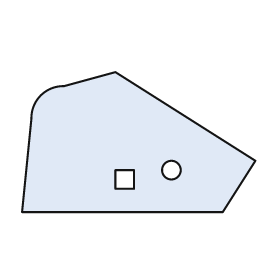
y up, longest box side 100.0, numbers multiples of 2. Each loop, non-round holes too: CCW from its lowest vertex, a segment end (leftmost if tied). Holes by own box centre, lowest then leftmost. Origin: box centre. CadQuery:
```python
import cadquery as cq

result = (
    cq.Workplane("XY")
    .moveTo(-50.0, -30.0)
    .lineTo(36.0, -30.0)
    .lineTo(50.0, -8.0)
    .lineTo(-10.0, 30.0)
    .lineTo(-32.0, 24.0)
    .threePointArc((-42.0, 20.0), (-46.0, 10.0))
    .close()
    .moveTo(-10.0, -20.0)
    .lineTo(-2.0, -20.0)
    .lineTo(-2.0, -12.0)
    .lineTo(-10.0, -12.0)
    .close()
    .moveTo(14.0, -12.0)
    .circle(4.0)
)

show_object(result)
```